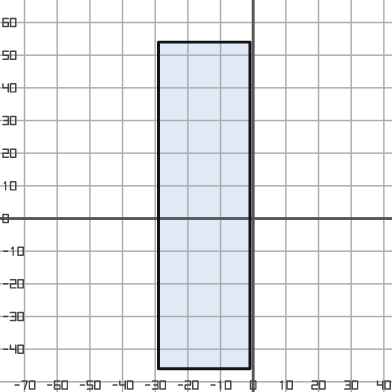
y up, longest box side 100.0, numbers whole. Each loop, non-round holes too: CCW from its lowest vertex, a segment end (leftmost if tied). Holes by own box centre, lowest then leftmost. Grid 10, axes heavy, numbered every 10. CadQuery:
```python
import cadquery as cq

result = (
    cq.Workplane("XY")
    .moveTo(-29.0, -46.0)
    .lineTo(-1.0, -46.0)
    .lineTo(-1.0, 54.0)
    .lineTo(-29.0, 54.0)
    .close()
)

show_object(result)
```